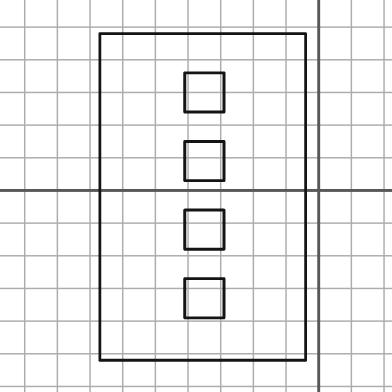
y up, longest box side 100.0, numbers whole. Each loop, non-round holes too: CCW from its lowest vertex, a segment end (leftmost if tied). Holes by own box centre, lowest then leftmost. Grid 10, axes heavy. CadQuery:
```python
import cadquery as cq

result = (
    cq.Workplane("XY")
    .moveTo(-67.0, -52.0)
    .lineTo(-4.0, -52.0)
    .lineTo(-4.0, 48.0)
    .lineTo(-67.0, 48.0)
    .close()
    .moveTo(-41.0, -39.0)
    .lineTo(-29.0, -39.0)
    .lineTo(-29.0, -27.0)
    .lineTo(-41.0, -27.0)
    .close()
    .moveTo(-41.0, -18.0)
    .lineTo(-29.0, -18.0)
    .lineTo(-29.0, -6.0)
    .lineTo(-41.0, -6.0)
    .close()
    .moveTo(-41.0, 3.0)
    .lineTo(-29.0, 3.0)
    .lineTo(-29.0, 15.0)
    .lineTo(-41.0, 15.0)
    .close()
    .moveTo(-41.0, 24.0)
    .lineTo(-29.0, 24.0)
    .lineTo(-29.0, 36.0)
    .lineTo(-41.0, 36.0)
    .close()
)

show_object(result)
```